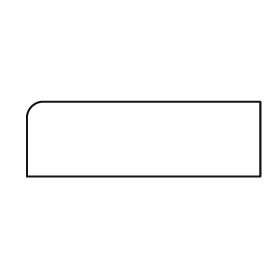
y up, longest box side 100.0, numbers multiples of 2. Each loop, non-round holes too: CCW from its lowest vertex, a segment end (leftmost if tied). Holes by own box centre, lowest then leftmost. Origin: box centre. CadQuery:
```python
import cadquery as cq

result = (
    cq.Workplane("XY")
    .moveTo(-50.0, -16.0)
    .lineTo(50.0, -16.0)
    .lineTo(50.0, 16.0)
    .lineTo(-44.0, 16.0)
    .threePointArc((-48.0, 14.0), (-50.0, 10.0))
    .close()
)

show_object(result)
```